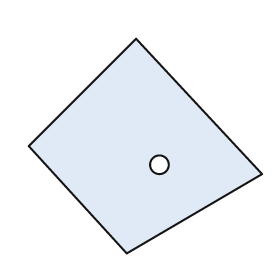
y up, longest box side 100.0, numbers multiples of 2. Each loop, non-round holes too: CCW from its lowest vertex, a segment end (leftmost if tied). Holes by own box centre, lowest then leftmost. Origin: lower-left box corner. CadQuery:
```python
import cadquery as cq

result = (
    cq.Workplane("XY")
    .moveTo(42.0, 0.0)
    .lineTo(100.0, 34.0)
    .lineTo(46.0, 92.0)
    .lineTo(0.0, 46.0)
    .close()
    .moveTo(56.0, 38.0)
    .circle(4.0)
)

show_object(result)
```